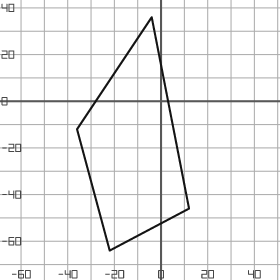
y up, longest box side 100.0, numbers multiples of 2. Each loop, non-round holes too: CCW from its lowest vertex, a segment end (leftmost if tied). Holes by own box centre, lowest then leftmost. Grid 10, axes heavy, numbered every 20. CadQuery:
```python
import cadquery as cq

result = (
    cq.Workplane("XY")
    .moveTo(-22.0, -64.0)
    .lineTo(12.0, -46.0)
    .lineTo(-4.0, 36.0)
    .lineTo(-36.0, -12.0)
    .close()
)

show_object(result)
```